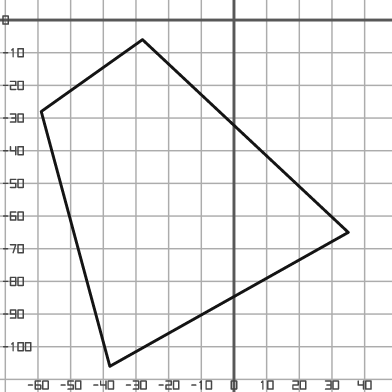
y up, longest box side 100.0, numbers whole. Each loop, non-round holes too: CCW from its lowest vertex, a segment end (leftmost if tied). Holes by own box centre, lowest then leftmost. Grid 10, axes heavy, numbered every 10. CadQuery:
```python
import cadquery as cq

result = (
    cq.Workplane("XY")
    .moveTo(-38.0, -106.0)
    .lineTo(35.0, -65.0)
    .lineTo(-28.0, -6.0)
    .lineTo(-59.0, -28.0)
    .close()
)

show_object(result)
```